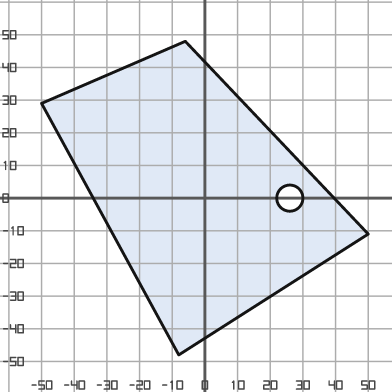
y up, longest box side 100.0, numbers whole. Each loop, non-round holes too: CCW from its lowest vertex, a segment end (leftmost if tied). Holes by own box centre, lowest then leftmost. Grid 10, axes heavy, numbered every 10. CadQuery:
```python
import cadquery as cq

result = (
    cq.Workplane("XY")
    .moveTo(-8.0, -48.0)
    .lineTo(50.0, -11.0)
    .lineTo(-6.0, 48.0)
    .lineTo(-50.0, 29.0)
    .close()
    .moveTo(26.0, 0.0)
    .circle(4.0)
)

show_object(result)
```